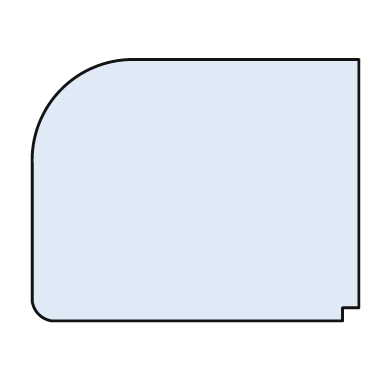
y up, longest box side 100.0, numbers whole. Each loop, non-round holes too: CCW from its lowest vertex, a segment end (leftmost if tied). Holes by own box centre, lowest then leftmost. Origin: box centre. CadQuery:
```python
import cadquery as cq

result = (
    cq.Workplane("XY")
    .moveTo(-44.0, -40.0)
    .lineTo(45.0, -40.0)
    .lineTo(45.0, -36.0)
    .lineTo(50.0, -36.0)
    .lineTo(50.0, 40.0)
    .lineTo(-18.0, 40.0)
    .threePointArc((-41.0, 31.0), (-50.0, 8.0))
    .lineTo(-50.0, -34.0)
    .threePointArc((-48.0, -38.0), (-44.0, -40.0))
    .close()
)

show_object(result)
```